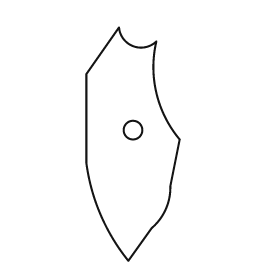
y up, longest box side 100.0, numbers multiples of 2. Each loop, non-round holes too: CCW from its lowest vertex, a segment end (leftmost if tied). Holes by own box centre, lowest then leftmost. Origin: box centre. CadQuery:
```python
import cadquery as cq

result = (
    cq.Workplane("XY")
    .moveTo(-2.0, -50.0)
    .lineTo(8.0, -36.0)
    .threePointArc((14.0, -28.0), (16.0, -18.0))
    .lineTo(20.0, 2.0)
    .threePointArc((10.0, 22.0), (10.0, 44.0))
    .threePointArc((0.0, 42.0), (-6.0, 50.0))
    .lineTo(-20.0, 30.0)
    .lineTo(-20.0, -8.0)
    .threePointArc((-14.0, -30.0), (-2.0, -50.0))
    .close()
    .moveTo(0.0, 6.0)
    .circle(4.0)
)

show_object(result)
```